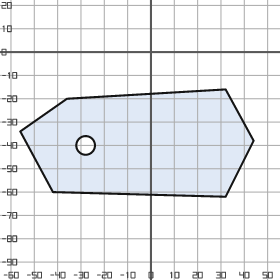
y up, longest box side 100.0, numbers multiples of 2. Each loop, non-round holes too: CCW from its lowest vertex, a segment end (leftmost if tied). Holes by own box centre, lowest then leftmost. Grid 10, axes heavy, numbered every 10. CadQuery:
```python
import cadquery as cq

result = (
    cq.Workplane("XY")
    .moveTo(32.0, -62.0)
    .lineTo(44.0, -38.0)
    .lineTo(32.0, -16.0)
    .lineTo(-36.0, -20.0)
    .lineTo(-56.0, -34.0)
    .lineTo(-42.0, -60.0)
    .close()
    .moveTo(-28.0, -40.0)
    .circle(4.0)
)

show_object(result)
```